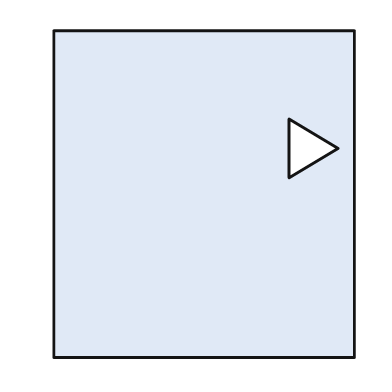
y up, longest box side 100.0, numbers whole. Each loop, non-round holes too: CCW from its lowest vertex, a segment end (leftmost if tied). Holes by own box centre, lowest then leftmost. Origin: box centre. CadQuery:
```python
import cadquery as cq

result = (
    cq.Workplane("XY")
    .moveTo(-46.0, -50.0)
    .lineTo(46.0, -50.0)
    .lineTo(46.0, 50.0)
    .lineTo(-46.0, 50.0)
    .close()
    .moveTo(26.0, 5.0)
    .lineTo(41.0, 14.0)
    .lineTo(26.0, 23.0)
    .close()
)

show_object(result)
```